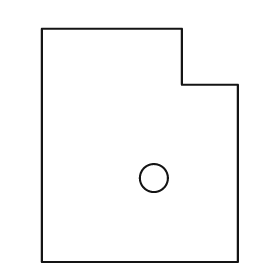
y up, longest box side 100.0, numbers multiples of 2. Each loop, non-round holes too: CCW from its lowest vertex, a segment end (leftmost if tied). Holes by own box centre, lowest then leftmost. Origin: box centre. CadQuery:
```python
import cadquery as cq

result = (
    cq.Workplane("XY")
    .moveTo(-42.0, -50.0)
    .lineTo(42.0, -50.0)
    .lineTo(42.0, 26.0)
    .lineTo(18.0, 26.0)
    .lineTo(18.0, 50.0)
    .lineTo(-42.0, 50.0)
    .close()
    .moveTo(6.0, -14.0)
    .circle(6.0)
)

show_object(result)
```